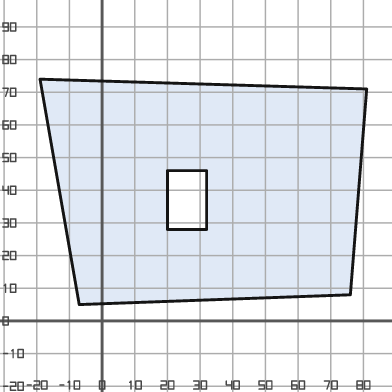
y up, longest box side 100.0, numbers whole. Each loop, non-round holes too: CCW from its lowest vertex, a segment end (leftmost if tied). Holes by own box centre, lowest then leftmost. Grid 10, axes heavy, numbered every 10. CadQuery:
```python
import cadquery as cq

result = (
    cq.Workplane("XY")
    .moveTo(-7.0, 5.0)
    .lineTo(76.0, 8.0)
    .lineTo(81.0, 71.0)
    .lineTo(-19.0, 74.0)
    .close()
    .moveTo(20.0, 28.0)
    .lineTo(32.0, 28.0)
    .lineTo(32.0, 46.0)
    .lineTo(20.0, 46.0)
    .close()
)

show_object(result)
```